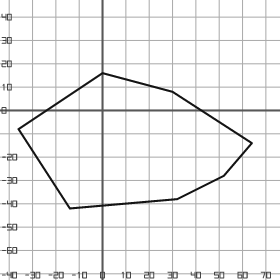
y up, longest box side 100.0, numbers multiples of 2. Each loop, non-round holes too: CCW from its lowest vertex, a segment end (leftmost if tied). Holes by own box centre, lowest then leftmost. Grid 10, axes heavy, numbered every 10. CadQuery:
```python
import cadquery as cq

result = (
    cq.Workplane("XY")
    .moveTo(-14.0, -42.0)
    .lineTo(32.0, -38.0)
    .lineTo(52.0, -28.0)
    .lineTo(64.0, -14.0)
    .lineTo(30.0, 8.0)
    .lineTo(0.0, 16.0)
    .lineTo(-36.0, -8.0)
    .close()
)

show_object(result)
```